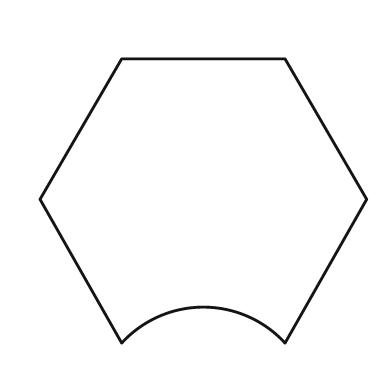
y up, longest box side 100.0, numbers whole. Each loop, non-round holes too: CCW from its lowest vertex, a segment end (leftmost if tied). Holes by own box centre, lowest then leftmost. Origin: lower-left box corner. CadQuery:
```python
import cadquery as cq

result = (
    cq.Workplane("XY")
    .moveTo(25.0, 0.0)
    .threePointArc((50.0, 11.0), (75.0, 0.0))
    .lineTo(100.0, 44.0)
    .lineTo(75.0, 87.0)
    .lineTo(25.0, 87.0)
    .lineTo(0.0, 44.0)
    .close()
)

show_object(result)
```